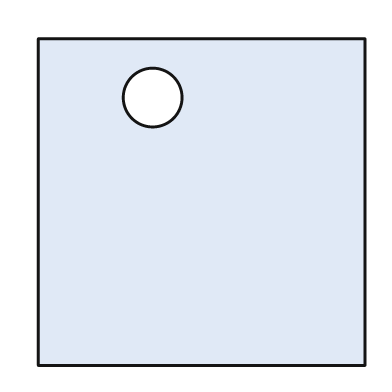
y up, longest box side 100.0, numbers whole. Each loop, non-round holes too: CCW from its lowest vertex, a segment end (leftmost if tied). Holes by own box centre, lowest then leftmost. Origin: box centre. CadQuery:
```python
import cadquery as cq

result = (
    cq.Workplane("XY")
    .moveTo(-50.0, -50.0)
    .lineTo(50.0, -50.0)
    .lineTo(50.0, 50.0)
    .lineTo(-50.0, 50.0)
    .close()
    .moveTo(-15.0, 32.0)
    .circle(9.0)
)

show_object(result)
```